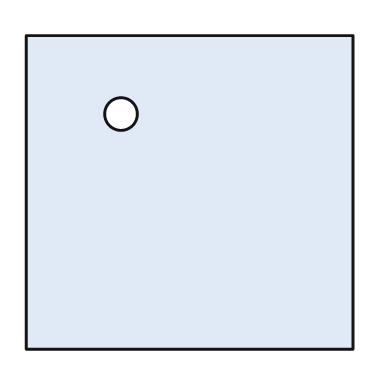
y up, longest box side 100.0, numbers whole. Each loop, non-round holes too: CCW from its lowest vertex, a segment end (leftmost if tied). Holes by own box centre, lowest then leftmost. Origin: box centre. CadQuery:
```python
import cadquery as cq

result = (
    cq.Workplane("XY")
    .moveTo(-50.0, -48.0)
    .lineTo(50.0, -48.0)
    .lineTo(50.0, 48.0)
    .lineTo(-50.0, 48.0)
    .close()
    .moveTo(-21.0, 24.0)
    .circle(5.0)
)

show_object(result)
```